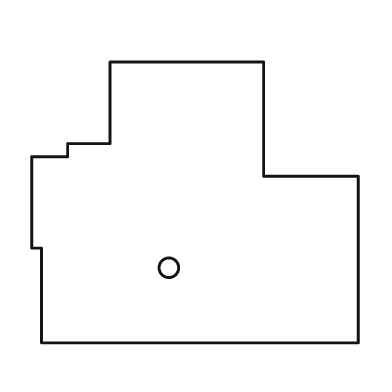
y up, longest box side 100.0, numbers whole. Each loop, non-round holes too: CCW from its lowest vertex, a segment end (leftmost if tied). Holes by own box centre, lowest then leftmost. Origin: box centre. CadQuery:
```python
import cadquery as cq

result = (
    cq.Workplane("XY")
    .moveTo(-47.0, -43.0)
    .lineTo(50.0, -43.0)
    .lineTo(50.0, 8.0)
    .lineTo(21.0, 8.0)
    .lineTo(21.0, 43.0)
    .lineTo(-26.0, 43.0)
    .lineTo(-26.0, 18.0)
    .lineTo(-39.0, 18.0)
    .lineTo(-39.0, 14.0)
    .lineTo(-50.0, 14.0)
    .lineTo(-50.0, -14.0)
    .lineTo(-47.0, -14.0)
    .close()
    .moveTo(-8.0, -20.0)
    .circle(3.0)
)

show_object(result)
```